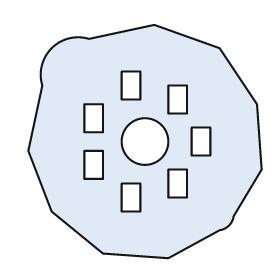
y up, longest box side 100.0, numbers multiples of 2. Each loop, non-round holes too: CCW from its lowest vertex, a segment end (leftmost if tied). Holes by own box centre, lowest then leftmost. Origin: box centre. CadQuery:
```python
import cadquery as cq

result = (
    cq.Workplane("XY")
    .moveTo(10.0, -50.0)
    .lineTo(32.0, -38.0)
    .threePointArc((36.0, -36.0), (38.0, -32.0))
    .lineTo(50.0, -12.0)
    .lineTo(48.0, 16.0)
    .lineTo(32.0, 40.0)
    .lineTo(4.0, 50.0)
    .lineTo(-24.0, 44.0)
    .threePointArc((-40.0, 40.0), (-44.0, 24.0))
    .lineTo(-50.0, -4.0)
    .lineTo(-40.0, -30.0)
    .lineTo(-18.0, -48.0)
    .close()
    .moveTo(-10.0, -30.0)
    .lineTo(-2.0, -30.0)
    .lineTo(-2.0, -18.0)
    .lineTo(-10.0, -18.0)
    .close()
    .moveTo(10.0, -24.0)
    .lineTo(18.0, -24.0)
    .lineTo(18.0, -12.0)
    .lineTo(10.0, -12.0)
    .close()
    .moveTo(-26.0, -16.0)
    .lineTo(-18.0, -16.0)
    .lineTo(-18.0, -4.0)
    .lineTo(-26.0, -4.0)
    .close()
    .moveTo(0.0, 0.0)
    .circle(10.0)
    .moveTo(20.0, -6.0)
    .lineTo(28.0, -6.0)
    .lineTo(28.0, 6.0)
    .lineTo(20.0, 6.0)
    .close()
    .moveTo(-26.0, 4.0)
    .lineTo(-18.0, 4.0)
    .lineTo(-18.0, 16.0)
    .lineTo(-26.0, 16.0)
    .close()
    .moveTo(10.0, 12.0)
    .lineTo(18.0, 12.0)
    .lineTo(18.0, 24.0)
    .lineTo(10.0, 24.0)
    .close()
    .moveTo(-10.0, 18.0)
    .lineTo(-2.0, 18.0)
    .lineTo(-2.0, 30.0)
    .lineTo(-10.0, 30.0)
    .close()
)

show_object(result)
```